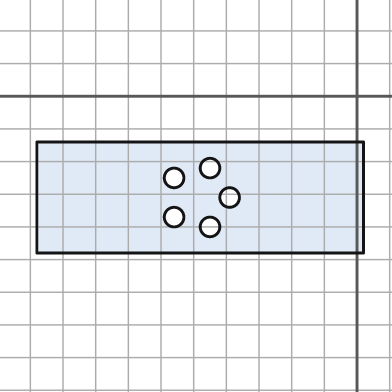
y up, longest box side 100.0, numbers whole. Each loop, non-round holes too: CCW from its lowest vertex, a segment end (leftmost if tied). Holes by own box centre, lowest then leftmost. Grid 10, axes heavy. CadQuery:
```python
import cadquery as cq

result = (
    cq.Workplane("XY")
    .moveTo(-98.0, -48.0)
    .lineTo(2.0, -48.0)
    .lineTo(2.0, -14.0)
    .lineTo(-98.0, -14.0)
    .close()
    .moveTo(-45.0, -40.0)
    .circle(3.0)
    .moveTo(-56.0, -37.0)
    .circle(3.0)
    .moveTo(-39.0, -31.0)
    .circle(3.0)
    .moveTo(-56.0, -25.0)
    .circle(3.0)
    .moveTo(-45.0, -22.0)
    .circle(3.0)
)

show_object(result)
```